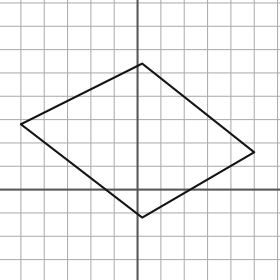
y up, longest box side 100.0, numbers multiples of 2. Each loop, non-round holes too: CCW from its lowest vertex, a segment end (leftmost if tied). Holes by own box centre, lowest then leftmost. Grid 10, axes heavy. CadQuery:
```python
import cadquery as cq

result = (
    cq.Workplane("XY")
    .moveTo(2.0, -12.0)
    .lineTo(50.0, 16.0)
    .lineTo(2.0, 54.0)
    .lineTo(-50.0, 28.0)
    .close()
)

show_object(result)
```